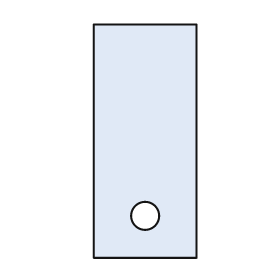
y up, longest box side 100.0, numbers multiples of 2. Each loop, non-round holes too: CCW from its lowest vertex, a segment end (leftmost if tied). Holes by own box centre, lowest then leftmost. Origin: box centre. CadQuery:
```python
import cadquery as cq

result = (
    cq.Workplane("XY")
    .moveTo(-22.0, -50.0)
    .lineTo(22.0, -50.0)
    .lineTo(22.0, 50.0)
    .lineTo(-22.0, 50.0)
    .close()
    .moveTo(0.0, -32.0)
    .circle(6.0)
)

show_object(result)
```